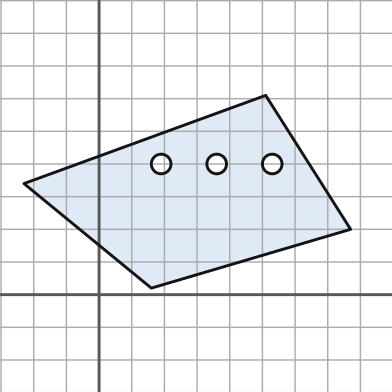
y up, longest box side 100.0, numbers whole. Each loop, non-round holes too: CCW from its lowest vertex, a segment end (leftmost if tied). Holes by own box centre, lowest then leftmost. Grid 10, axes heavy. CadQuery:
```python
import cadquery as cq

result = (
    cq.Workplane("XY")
    .moveTo(16.0, 2.0)
    .lineTo(77.0, 20.0)
    .lineTo(51.0, 61.0)
    .lineTo(-23.0, 34.0)
    .close()
    .moveTo(19.0, 40.0)
    .circle(3.0)
    .moveTo(36.0, 40.0)
    .circle(3.0)
    .moveTo(53.0, 40.0)
    .circle(3.0)
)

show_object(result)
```